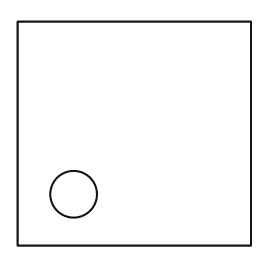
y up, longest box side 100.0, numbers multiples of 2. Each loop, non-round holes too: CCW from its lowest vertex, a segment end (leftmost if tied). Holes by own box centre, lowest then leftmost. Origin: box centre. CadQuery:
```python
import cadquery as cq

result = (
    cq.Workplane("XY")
    .moveTo(-50.0, -48.0)
    .lineTo(50.0, -48.0)
    .lineTo(50.0, 48.0)
    .lineTo(-50.0, 48.0)
    .close()
    .moveTo(-26.0, -26.0)
    .circle(10.0)
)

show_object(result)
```